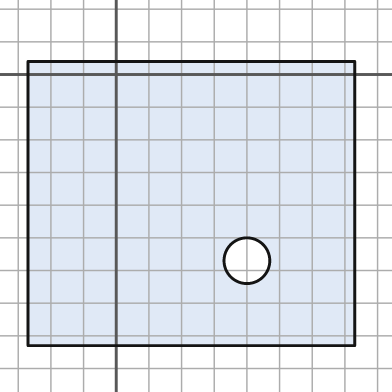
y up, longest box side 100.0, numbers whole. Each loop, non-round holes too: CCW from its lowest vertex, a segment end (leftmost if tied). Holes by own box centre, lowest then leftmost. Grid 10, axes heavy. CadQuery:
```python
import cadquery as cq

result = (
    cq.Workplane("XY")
    .moveTo(-27.0, -83.0)
    .lineTo(73.0, -83.0)
    .lineTo(73.0, 4.0)
    .lineTo(-27.0, 4.0)
    .close()
    .moveTo(40.0, -57.0)
    .circle(7.0)
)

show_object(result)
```